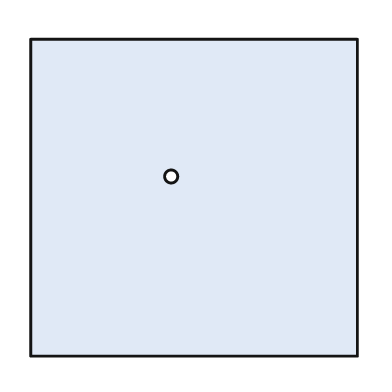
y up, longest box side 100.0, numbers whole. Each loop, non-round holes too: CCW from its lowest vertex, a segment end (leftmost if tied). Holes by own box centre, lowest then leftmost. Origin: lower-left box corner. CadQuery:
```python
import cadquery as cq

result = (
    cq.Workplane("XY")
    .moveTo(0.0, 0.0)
    .lineTo(100.0, 0.0)
    .lineTo(100.0, 97.0)
    .lineTo(0.0, 97.0)
    .close()
    .moveTo(43.0, 55.0)
    .circle(2.0)
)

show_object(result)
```